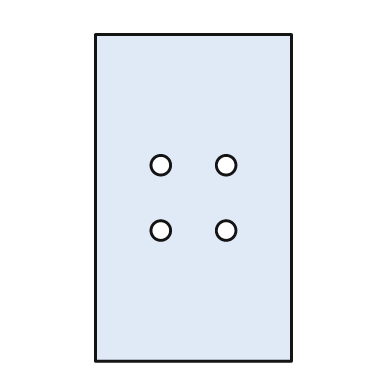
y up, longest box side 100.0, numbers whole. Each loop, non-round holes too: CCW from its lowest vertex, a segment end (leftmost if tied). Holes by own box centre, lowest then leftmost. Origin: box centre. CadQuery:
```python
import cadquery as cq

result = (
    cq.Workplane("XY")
    .moveTo(-30.0, -50.0)
    .lineTo(30.0, -50.0)
    .lineTo(30.0, 50.0)
    .lineTo(-30.0, 50.0)
    .close()
    .moveTo(-10.0, -10.0)
    .circle(3.0)
    .moveTo(10.0, -10.0)
    .circle(3.0)
    .moveTo(-10.0, 10.0)
    .circle(3.0)
    .moveTo(10.0, 10.0)
    .circle(3.0)
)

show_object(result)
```